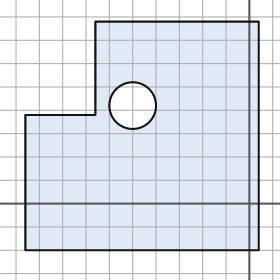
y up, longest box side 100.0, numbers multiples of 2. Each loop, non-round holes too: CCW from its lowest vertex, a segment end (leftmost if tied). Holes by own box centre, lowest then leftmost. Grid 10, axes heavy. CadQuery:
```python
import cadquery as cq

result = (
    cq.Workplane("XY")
    .moveTo(-96.0, -20.0)
    .lineTo(4.0, -20.0)
    .lineTo(4.0, 78.0)
    .lineTo(-66.0, 78.0)
    .lineTo(-66.0, 38.0)
    .lineTo(-96.0, 38.0)
    .close()
    .moveTo(-50.0, 42.0)
    .circle(10.0)
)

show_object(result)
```